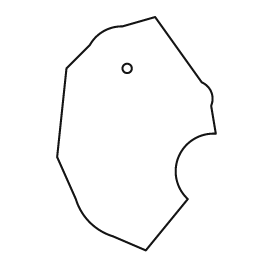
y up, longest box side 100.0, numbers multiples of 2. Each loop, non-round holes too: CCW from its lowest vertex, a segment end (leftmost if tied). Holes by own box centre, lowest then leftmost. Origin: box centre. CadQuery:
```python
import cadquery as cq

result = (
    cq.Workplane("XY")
    .moveTo(4.0, -50.0)
    .lineTo(22.0, -28.0)
    .threePointArc((18.0, -10.0), (34.0, 0.0))
    .lineTo(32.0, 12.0)
    .threePointArc((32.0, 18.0), (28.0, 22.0))
    .lineTo(8.0, 50.0)
    .lineTo(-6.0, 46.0)
    .threePointArc((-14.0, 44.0), (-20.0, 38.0))
    .lineTo(-30.0, 28.0)
    .lineTo(-34.0, -10.0)
    .lineTo(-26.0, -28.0)
    .threePointArc((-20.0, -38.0), (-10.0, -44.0))
    .close()
    .moveTo(-4.0, 28.0)
    .circle(2.0)
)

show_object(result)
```